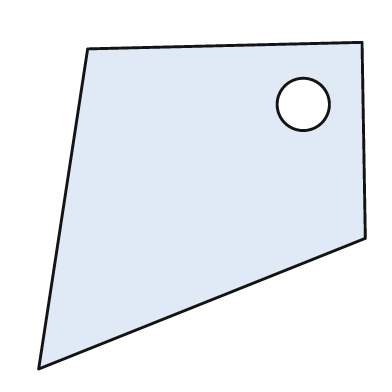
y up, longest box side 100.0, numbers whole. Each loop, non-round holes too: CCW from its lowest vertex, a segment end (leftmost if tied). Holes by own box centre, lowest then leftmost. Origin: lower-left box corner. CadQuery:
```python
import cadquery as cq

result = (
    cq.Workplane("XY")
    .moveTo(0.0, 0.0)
    .lineTo(100.0, 40.0)
    .lineTo(99.0, 100.0)
    .lineTo(15.0, 98.0)
    .close()
    .moveTo(81.0, 81.0)
    .circle(8.0)
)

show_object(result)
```